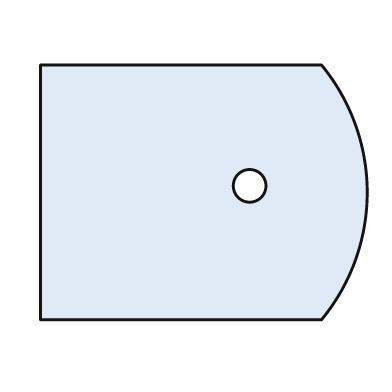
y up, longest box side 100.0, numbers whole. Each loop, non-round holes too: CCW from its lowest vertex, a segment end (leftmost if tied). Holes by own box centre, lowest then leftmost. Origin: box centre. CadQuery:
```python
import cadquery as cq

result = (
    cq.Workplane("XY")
    .moveTo(-50.0, -39.0)
    .lineTo(36.0, -39.0)
    .threePointArc((50.0, 0.0), (36.0, 39.0))
    .lineTo(-50.0, 39.0)
    .close()
    .moveTo(14.0, 2.0)
    .circle(5.0)
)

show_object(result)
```